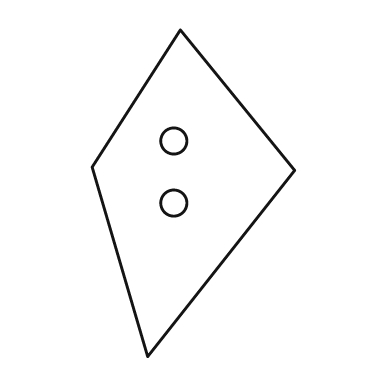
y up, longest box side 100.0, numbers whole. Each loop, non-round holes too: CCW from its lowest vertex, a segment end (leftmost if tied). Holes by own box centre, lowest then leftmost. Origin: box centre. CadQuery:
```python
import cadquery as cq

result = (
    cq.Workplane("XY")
    .moveTo(-14.0, -50.0)
    .lineTo(31.0, 7.0)
    .lineTo(-4.0, 50.0)
    .lineTo(-31.0, 8.0)
    .close()
    .moveTo(-6.0, -3.0)
    .circle(4.0)
    .moveTo(-6.0, 16.0)
    .circle(4.0)
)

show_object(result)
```